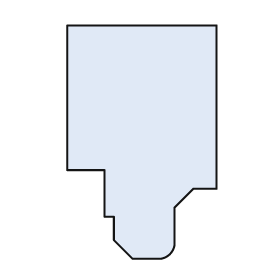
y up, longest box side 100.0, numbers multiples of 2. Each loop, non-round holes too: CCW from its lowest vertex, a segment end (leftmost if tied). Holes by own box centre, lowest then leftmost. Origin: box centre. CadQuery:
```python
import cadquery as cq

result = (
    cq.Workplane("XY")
    .moveTo(-4.0, -50.0)
    .lineTo(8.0, -50.0)
    .threePointArc((12.0, -48.0), (14.0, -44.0))
    .lineTo(14.0, -28.0)
    .lineTo(22.0, -20.0)
    .lineTo(32.0, -20.0)
    .lineTo(32.0, 50.0)
    .lineTo(-32.0, 50.0)
    .lineTo(-32.0, -12.0)
    .lineTo(-16.0, -12.0)
    .lineTo(-16.0, -32.0)
    .lineTo(-12.0, -32.0)
    .lineTo(-12.0, -42.0)
    .close()
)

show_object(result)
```